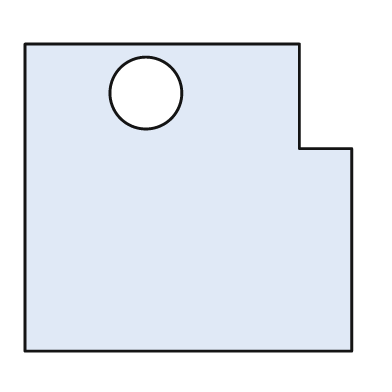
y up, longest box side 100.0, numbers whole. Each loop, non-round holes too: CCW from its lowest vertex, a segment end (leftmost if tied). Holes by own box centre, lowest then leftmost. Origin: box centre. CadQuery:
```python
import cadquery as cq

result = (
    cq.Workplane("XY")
    .moveTo(-50.0, -47.0)
    .lineTo(50.0, -47.0)
    .lineTo(50.0, 15.0)
    .lineTo(34.0, 15.0)
    .lineTo(34.0, 47.0)
    .lineTo(-50.0, 47.0)
    .close()
    .moveTo(-13.0, 32.0)
    .circle(11.0)
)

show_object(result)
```